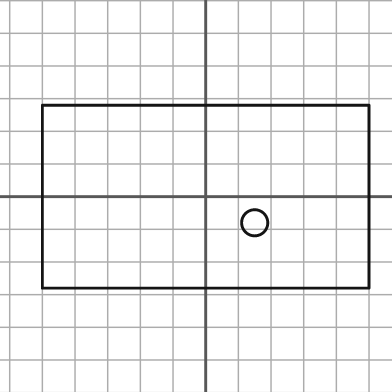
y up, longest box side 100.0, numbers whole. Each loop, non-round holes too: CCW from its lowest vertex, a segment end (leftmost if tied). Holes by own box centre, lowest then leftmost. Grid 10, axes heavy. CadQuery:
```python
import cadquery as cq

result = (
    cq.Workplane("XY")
    .moveTo(-50.0, -28.0)
    .lineTo(50.0, -28.0)
    .lineTo(50.0, 28.0)
    .lineTo(-50.0, 28.0)
    .close()
    .moveTo(15.0, -8.0)
    .circle(4.0)
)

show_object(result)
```